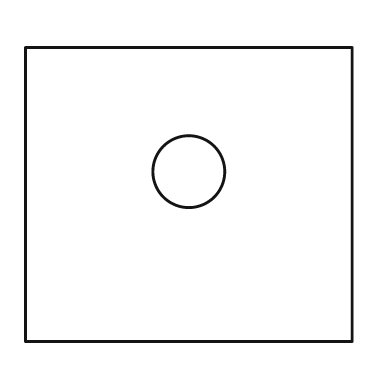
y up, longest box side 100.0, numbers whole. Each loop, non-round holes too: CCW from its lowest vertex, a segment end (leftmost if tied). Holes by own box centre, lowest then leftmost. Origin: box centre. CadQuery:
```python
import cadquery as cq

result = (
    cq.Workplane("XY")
    .moveTo(-50.0, -45.0)
    .lineTo(50.0, -45.0)
    .lineTo(50.0, 45.0)
    .lineTo(-50.0, 45.0)
    .close()
    .moveTo(0.0, 7.0)
    .circle(11.0)
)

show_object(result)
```